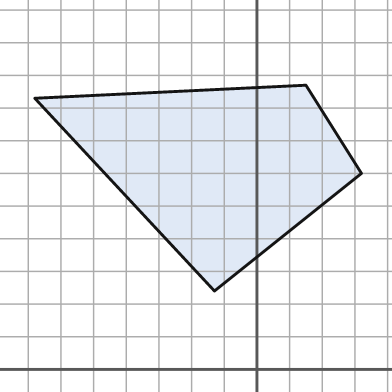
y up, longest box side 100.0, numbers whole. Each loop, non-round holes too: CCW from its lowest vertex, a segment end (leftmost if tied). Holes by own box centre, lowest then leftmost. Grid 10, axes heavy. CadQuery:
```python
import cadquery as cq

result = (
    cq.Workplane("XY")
    .moveTo(-13.0, 24.0)
    .lineTo(32.0, 60.0)
    .lineTo(15.0, 87.0)
    .lineTo(-68.0, 83.0)
    .close()
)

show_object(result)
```